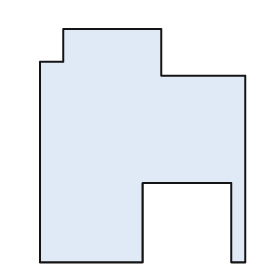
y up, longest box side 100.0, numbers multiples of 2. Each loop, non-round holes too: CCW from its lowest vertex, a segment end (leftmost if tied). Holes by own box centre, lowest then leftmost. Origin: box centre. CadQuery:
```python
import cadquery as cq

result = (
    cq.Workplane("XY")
    .moveTo(-44.0, -50.0)
    .lineTo(0.0, -50.0)
    .lineTo(0.0, -16.0)
    .lineTo(38.0, -16.0)
    .lineTo(38.0, -50.0)
    .lineTo(44.0, -50.0)
    .lineTo(44.0, 30.0)
    .lineTo(8.0, 30.0)
    .lineTo(8.0, 50.0)
    .lineTo(-34.0, 50.0)
    .lineTo(-34.0, 36.0)
    .lineTo(-44.0, 36.0)
    .close()
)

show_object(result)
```